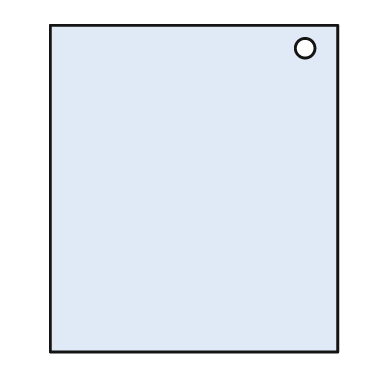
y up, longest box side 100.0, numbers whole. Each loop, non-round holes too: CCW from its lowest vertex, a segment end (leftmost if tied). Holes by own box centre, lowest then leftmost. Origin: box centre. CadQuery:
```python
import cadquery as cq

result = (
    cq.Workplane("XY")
    .moveTo(-44.0, -50.0)
    .lineTo(44.0, -50.0)
    .lineTo(44.0, 50.0)
    .lineTo(-44.0, 50.0)
    .close()
    .moveTo(34.0, 43.0)
    .circle(3.0)
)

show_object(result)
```